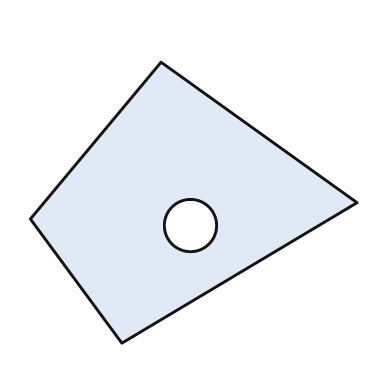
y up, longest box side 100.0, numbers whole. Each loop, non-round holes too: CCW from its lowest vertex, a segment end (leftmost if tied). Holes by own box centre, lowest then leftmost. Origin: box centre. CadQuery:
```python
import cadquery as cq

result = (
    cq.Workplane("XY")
    .moveTo(-22.0, -43.0)
    .lineTo(50.0, 0.0)
    .lineTo(-10.0, 43.0)
    .lineTo(-50.0, -5.0)
    .close()
    .moveTo(-1.0, -7.0)
    .circle(8.0)
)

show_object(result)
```